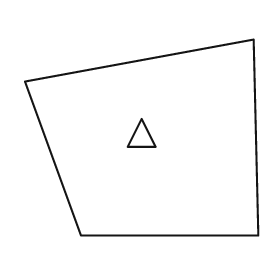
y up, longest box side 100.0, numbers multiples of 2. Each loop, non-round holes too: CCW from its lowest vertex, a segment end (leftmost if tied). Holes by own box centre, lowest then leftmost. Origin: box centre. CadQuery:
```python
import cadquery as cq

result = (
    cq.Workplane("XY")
    .moveTo(-26.0, -42.0)
    .lineTo(50.0, -42.0)
    .lineTo(48.0, 42.0)
    .lineTo(-50.0, 24.0)
    .close()
    .moveTo(-6.0, -4.0)
    .lineTo(6.0, -4.0)
    .lineTo(0.0, 8.0)
    .close()
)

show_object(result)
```